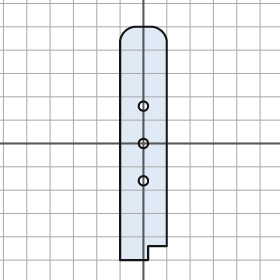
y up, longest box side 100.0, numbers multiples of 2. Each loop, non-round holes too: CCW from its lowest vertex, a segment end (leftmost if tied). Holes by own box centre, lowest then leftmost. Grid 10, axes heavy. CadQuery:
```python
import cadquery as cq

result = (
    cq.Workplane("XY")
    .moveTo(-10.0, -50.0)
    .lineTo(2.0, -50.0)
    .lineTo(2.0, -44.0)
    .lineTo(10.0, -44.0)
    .lineTo(10.0, 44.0)
    .threePointArc((8.0, 48.0), (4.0, 50.0))
    .lineTo(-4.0, 50.0)
    .threePointArc((-8.0, 48.0), (-10.0, 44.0))
    .close()
    .moveTo(0.0, -16.0)
    .circle(2.0)
    .moveTo(0.0, 0.0)
    .circle(2.0)
    .moveTo(0.0, 16.0)
    .circle(2.0)
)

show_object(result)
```